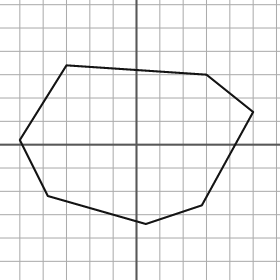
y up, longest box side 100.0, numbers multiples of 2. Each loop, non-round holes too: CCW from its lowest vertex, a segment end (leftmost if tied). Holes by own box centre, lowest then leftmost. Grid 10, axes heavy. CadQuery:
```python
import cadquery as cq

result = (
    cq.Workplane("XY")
    .moveTo(4.0, -34.0)
    .lineTo(28.0, -26.0)
    .lineTo(50.0, 14.0)
    .lineTo(30.0, 30.0)
    .lineTo(-30.0, 34.0)
    .lineTo(-50.0, 2.0)
    .lineTo(-38.0, -22.0)
    .close()
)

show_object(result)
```